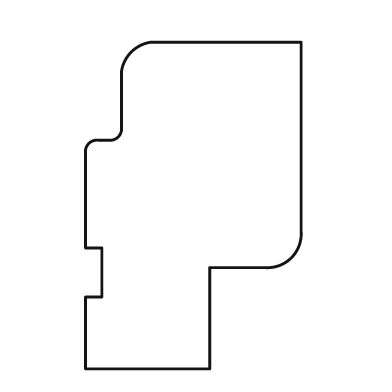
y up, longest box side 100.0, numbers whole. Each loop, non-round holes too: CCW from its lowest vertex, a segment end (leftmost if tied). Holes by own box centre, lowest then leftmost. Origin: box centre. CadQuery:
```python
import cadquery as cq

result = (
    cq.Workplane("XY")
    .moveTo(-33.0, -50.0)
    .lineTo(5.0, -50.0)
    .lineTo(5.0, -19.0)
    .lineTo(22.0, -19.0)
    .threePointArc((30.0, -16.0), (33.0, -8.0))
    .lineTo(33.0, 50.0)
    .lineTo(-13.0, 50.0)
    .threePointArc((-19.0, 47.0), (-22.0, 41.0))
    .lineTo(-22.0, 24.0)
    .threePointArc((-23.0, 21.0), (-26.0, 20.0))
    .lineTo(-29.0, 20.0)
    .threePointArc((-32.0, 19.0), (-33.0, 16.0))
    .lineTo(-33.0, -13.0)
    .lineTo(-28.0, -13.0)
    .lineTo(-28.0, -28.0)
    .lineTo(-33.0, -28.0)
    .close()
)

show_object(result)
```